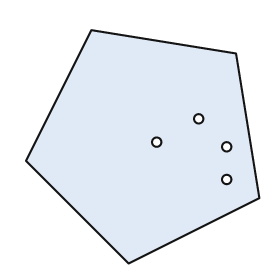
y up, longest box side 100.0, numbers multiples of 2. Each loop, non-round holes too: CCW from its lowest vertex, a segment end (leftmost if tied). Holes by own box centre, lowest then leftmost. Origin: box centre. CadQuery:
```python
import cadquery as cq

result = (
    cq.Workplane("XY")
    .moveTo(-6.0, -50.0)
    .lineTo(50.0, -22.0)
    .lineTo(40.0, 40.0)
    .lineTo(-22.0, 50.0)
    .lineTo(-50.0, -6.0)
    .close()
    .moveTo(36.0, -14.0)
    .circle(2.0)
    .moveTo(36.0, 0.0)
    .circle(2.0)
    .moveTo(6.0, 2.0)
    .circle(2.0)
    .moveTo(24.0, 12.0)
    .circle(2.0)
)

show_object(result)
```